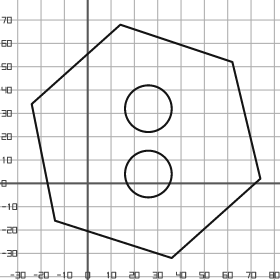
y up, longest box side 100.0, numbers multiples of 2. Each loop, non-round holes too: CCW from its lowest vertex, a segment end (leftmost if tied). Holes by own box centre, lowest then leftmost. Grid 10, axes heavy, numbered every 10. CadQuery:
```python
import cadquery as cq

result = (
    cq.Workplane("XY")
    .moveTo(36.0, -32.0)
    .lineTo(74.0, 2.0)
    .lineTo(62.0, 52.0)
    .lineTo(14.0, 68.0)
    .lineTo(-24.0, 34.0)
    .lineTo(-14.0, -16.0)
    .close()
    .moveTo(26.0, 4.0)
    .circle(10.0)
    .moveTo(26.0, 32.0)
    .circle(10.0)
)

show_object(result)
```